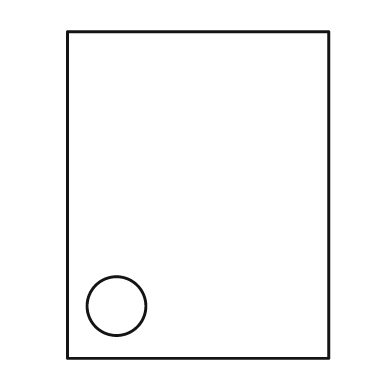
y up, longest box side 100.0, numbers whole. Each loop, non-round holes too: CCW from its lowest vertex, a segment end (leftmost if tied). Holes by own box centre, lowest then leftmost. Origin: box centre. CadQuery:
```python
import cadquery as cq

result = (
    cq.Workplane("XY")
    .moveTo(-40.0, -50.0)
    .lineTo(40.0, -50.0)
    .lineTo(40.0, 50.0)
    .lineTo(-40.0, 50.0)
    .close()
    .moveTo(-25.0, -34.0)
    .circle(9.0)
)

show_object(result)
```